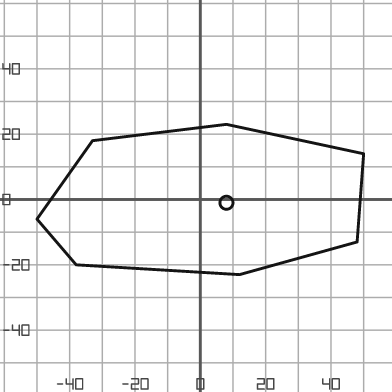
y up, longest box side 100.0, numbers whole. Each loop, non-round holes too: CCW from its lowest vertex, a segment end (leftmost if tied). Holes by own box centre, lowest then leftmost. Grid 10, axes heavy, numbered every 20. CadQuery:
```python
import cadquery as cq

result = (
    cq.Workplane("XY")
    .moveTo(12.0, -23.0)
    .lineTo(48.0, -13.0)
    .lineTo(50.0, 14.0)
    .lineTo(8.0, 23.0)
    .lineTo(-33.0, 18.0)
    .lineTo(-50.0, -6.0)
    .lineTo(-38.0, -20.0)
    .close()
    .moveTo(8.0, -1.0)
    .circle(2.0)
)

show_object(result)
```